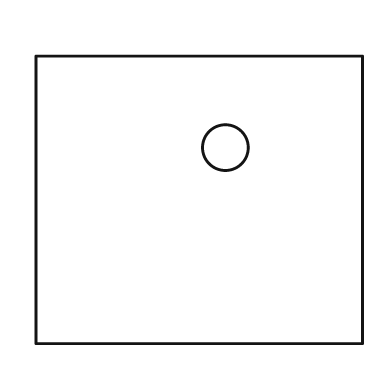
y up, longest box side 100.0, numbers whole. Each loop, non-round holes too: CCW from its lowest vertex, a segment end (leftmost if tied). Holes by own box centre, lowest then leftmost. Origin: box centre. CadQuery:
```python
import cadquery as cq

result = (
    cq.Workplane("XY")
    .moveTo(-50.0, -44.0)
    .lineTo(50.0, -44.0)
    .lineTo(50.0, 44.0)
    .lineTo(-50.0, 44.0)
    .close()
    .moveTo(8.0, 16.0)
    .circle(7.0)
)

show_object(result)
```